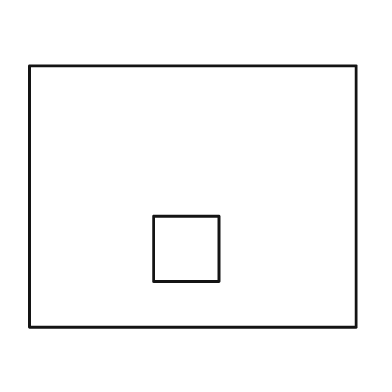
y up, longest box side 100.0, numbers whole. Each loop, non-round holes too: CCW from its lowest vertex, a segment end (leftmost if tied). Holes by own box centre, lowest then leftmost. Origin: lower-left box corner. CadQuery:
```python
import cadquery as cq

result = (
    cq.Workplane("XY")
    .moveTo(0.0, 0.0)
    .lineTo(100.0, 0.0)
    .lineTo(100.0, 80.0)
    .lineTo(0.0, 80.0)
    .close()
    .moveTo(38.0, 14.0)
    .lineTo(58.0, 14.0)
    .lineTo(58.0, 34.0)
    .lineTo(38.0, 34.0)
    .close()
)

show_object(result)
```